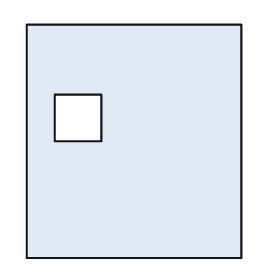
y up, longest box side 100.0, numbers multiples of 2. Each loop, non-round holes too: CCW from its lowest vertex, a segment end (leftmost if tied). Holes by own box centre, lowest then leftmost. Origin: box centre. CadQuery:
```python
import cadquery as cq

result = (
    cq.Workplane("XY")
    .moveTo(-46.0, -50.0)
    .lineTo(46.0, -50.0)
    .lineTo(46.0, 50.0)
    .lineTo(-46.0, 50.0)
    .close()
    .moveTo(-34.0, 0.0)
    .lineTo(-14.0, 0.0)
    .lineTo(-14.0, 20.0)
    .lineTo(-34.0, 20.0)
    .close()
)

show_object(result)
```